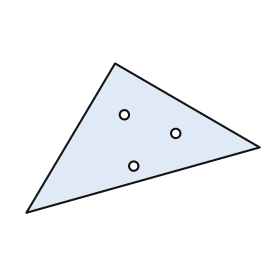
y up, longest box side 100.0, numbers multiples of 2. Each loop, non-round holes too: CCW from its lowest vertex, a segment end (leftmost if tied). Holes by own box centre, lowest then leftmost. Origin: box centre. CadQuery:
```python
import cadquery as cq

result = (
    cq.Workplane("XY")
    .moveTo(-50.0, -32.0)
    .lineTo(50.0, -4.0)
    .lineTo(-12.0, 32.0)
    .close()
    .moveTo(-4.0, -12.0)
    .circle(2.0)
    .moveTo(14.0, 2.0)
    .circle(2.0)
    .moveTo(-8.0, 10.0)
    .circle(2.0)
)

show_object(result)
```